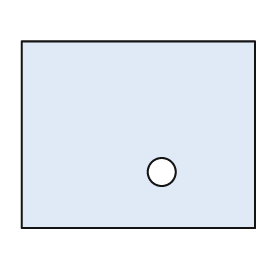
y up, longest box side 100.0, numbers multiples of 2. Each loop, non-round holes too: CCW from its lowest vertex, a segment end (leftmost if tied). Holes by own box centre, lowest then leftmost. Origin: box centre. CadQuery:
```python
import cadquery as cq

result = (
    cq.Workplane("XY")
    .moveTo(-50.0, -40.0)
    .lineTo(50.0, -40.0)
    .lineTo(50.0, 40.0)
    .lineTo(-50.0, 40.0)
    .close()
    .moveTo(10.0, -16.0)
    .circle(6.0)
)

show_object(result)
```